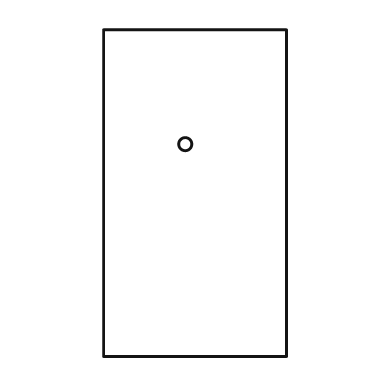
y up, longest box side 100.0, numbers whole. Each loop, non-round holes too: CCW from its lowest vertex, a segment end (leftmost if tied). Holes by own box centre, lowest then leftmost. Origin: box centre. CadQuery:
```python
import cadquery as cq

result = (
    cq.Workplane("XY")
    .moveTo(-28.0, -50.0)
    .lineTo(28.0, -50.0)
    .lineTo(28.0, 50.0)
    .lineTo(-28.0, 50.0)
    .close()
    .moveTo(-3.0, 15.0)
    .circle(2.0)
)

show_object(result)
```